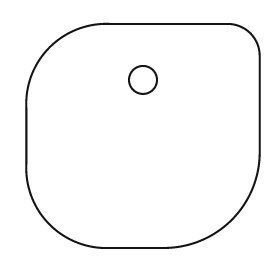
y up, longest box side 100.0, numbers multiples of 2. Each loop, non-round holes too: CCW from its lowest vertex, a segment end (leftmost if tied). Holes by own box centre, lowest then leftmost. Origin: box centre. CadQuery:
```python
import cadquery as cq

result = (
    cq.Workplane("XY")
    .moveTo(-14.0, -48.0)
    .lineTo(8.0, -48.0)
    .threePointArc((38.0, -36.0), (50.0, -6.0))
    .lineTo(50.0, 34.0)
    .threePointArc((46.0, 44.0), (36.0, 48.0))
    .lineTo(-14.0, 48.0)
    .threePointArc((-40.0, 38.0), (-50.0, 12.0))
    .lineTo(-50.0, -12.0)
    .threePointArc((-40.0, -38.0), (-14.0, -48.0))
    .close()
    .moveTo(0.0, 24.0)
    .circle(6.0)
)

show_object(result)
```